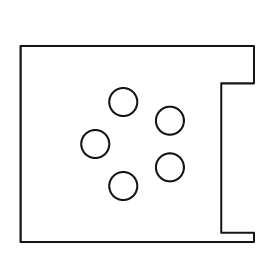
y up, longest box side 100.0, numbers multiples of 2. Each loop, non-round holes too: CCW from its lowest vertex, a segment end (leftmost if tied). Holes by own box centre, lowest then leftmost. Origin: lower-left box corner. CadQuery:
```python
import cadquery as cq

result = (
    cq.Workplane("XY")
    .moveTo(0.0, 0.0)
    .lineTo(100.0, 0.0)
    .lineTo(100.0, 4.0)
    .lineTo(86.0, 4.0)
    .lineTo(86.0, 68.0)
    .lineTo(100.0, 68.0)
    .lineTo(100.0, 84.0)
    .lineTo(0.0, 84.0)
    .close()
    .moveTo(44.0, 24.0)
    .circle(6.0)
    .moveTo(64.0, 32.0)
    .circle(6.0)
    .moveTo(32.0, 42.0)
    .circle(6.0)
    .moveTo(64.0, 52.0)
    .circle(6.0)
    .moveTo(44.0, 60.0)
    .circle(6.0)
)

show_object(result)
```